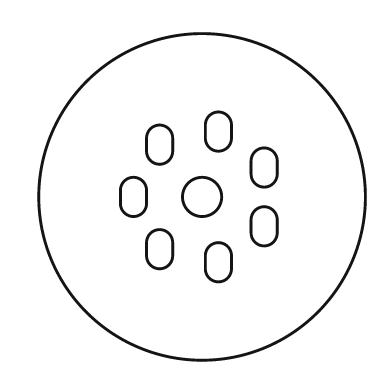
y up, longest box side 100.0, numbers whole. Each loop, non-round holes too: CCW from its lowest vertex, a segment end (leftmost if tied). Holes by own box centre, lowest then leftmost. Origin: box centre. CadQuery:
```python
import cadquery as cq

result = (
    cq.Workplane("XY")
    .moveTo(0.0, 0.0)
    .circle(50.0)
    .moveTo(1.0, -22.0)
    .threePointArc((5.0, -26.0), (9.0, -22.0))
    .lineTo(9.0, -18.0)
    .threePointArc((5.0, -14.0), (1.0, -18.0))
    .close()
    .moveTo(-17.0, -18.0)
    .threePointArc((-13.0, -22.0), (-9.0, -18.0))
    .lineTo(-9.0, -14.0)
    .threePointArc((-13.0, -10.0), (-17.0, -14.0))
    .close()
    .moveTo(15.0, -11.0)
    .threePointArc((19.0, -15.0), (23.0, -11.0))
    .lineTo(23.0, -7.0)
    .threePointArc((19.0, -3.0), (15.0, -7.0))
    .close()
    .moveTo(-25.0, -2.0)
    .threePointArc((-21.0, -6.0), (-17.0, -2.0))
    .lineTo(-17.0, 2.0)
    .threePointArc((-21.0, 6.0), (-25.0, 2.0))
    .close()
    .moveTo(0.0, 0.0)
    .circle(6.0)
    .moveTo(15.0, 7.0)
    .threePointArc((19.0, 3.0), (23.0, 7.0))
    .lineTo(23.0, 11.0)
    .threePointArc((19.0, 15.0), (15.0, 11.0))
    .close()
    .moveTo(-17.0, 14.0)
    .threePointArc((-13.0, 10.0), (-9.0, 14.0))
    .lineTo(-9.0, 18.0)
    .threePointArc((-13.0, 22.0), (-17.0, 18.0))
    .close()
    .moveTo(1.0, 18.0)
    .threePointArc((5.0, 14.0), (9.0, 18.0))
    .lineTo(9.0, 22.0)
    .threePointArc((5.0, 26.0), (1.0, 22.0))
    .close()
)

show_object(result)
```